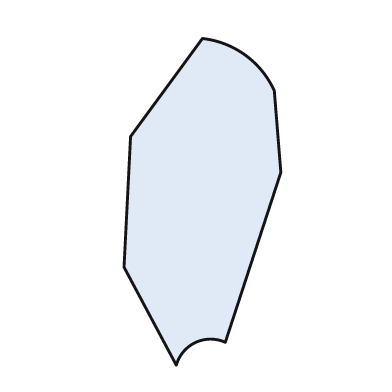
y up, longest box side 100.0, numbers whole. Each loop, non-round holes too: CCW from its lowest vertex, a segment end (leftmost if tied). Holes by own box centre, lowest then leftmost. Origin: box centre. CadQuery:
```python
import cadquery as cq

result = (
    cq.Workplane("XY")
    .moveTo(-8.0, -50.0)
    .threePointArc((-2.0, -43.0), (7.0, -43.0))
    .lineTo(24.0, 9.0)
    .lineTo(22.0, 34.0)
    .threePointArc((13.0, 45.0), (0.0, 50.0))
    .lineTo(-22.0, 20.0)
    .lineTo(-24.0, -20.0)
    .close()
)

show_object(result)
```